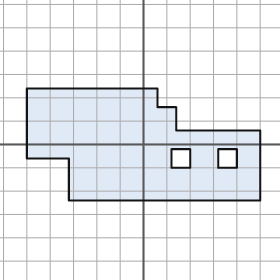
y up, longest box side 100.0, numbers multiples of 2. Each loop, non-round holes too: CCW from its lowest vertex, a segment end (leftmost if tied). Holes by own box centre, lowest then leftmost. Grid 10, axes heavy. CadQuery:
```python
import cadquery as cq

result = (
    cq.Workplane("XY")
    .moveTo(-32.0, -24.0)
    .lineTo(50.0, -24.0)
    .lineTo(50.0, 6.0)
    .lineTo(14.0, 6.0)
    .lineTo(14.0, 16.0)
    .lineTo(6.0, 16.0)
    .lineTo(6.0, 24.0)
    .lineTo(-50.0, 24.0)
    .lineTo(-50.0, -6.0)
    .lineTo(-32.0, -6.0)
    .close()
    .moveTo(12.0, -10.0)
    .lineTo(20.0, -10.0)
    .lineTo(20.0, -2.0)
    .lineTo(12.0, -2.0)
    .close()
    .moveTo(32.0, -10.0)
    .lineTo(40.0, -10.0)
    .lineTo(40.0, -2.0)
    .lineTo(32.0, -2.0)
    .close()
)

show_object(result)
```